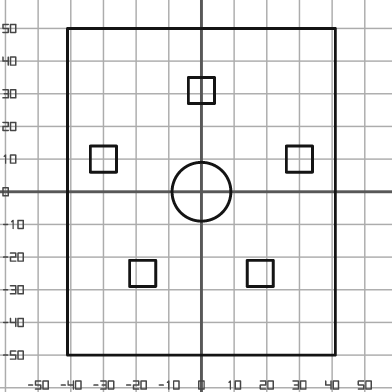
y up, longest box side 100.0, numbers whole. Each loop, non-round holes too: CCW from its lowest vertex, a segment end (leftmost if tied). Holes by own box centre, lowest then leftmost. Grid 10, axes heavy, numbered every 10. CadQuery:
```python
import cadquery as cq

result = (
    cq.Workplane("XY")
    .moveTo(-41.0, -50.0)
    .lineTo(41.0, -50.0)
    .lineTo(41.0, 50.0)
    .lineTo(-41.0, 50.0)
    .close()
    .moveTo(-22.0, -29.0)
    .lineTo(-14.0, -29.0)
    .lineTo(-14.0, -21.0)
    .lineTo(-22.0, -21.0)
    .close()
    .moveTo(14.0, -29.0)
    .lineTo(22.0, -29.0)
    .lineTo(22.0, -21.0)
    .lineTo(14.0, -21.0)
    .close()
    .moveTo(0.0, 0.0)
    .circle(9.0)
    .moveTo(-34.0, 6.0)
    .lineTo(-26.0, 6.0)
    .lineTo(-26.0, 14.0)
    .lineTo(-34.0, 14.0)
    .close()
    .moveTo(26.0, 6.0)
    .lineTo(34.0, 6.0)
    .lineTo(34.0, 14.0)
    .lineTo(26.0, 14.0)
    .close()
    .moveTo(-4.0, 27.0)
    .lineTo(4.0, 27.0)
    .lineTo(4.0, 35.0)
    .lineTo(-4.0, 35.0)
    .close()
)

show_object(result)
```